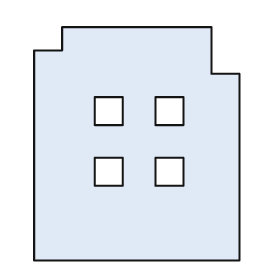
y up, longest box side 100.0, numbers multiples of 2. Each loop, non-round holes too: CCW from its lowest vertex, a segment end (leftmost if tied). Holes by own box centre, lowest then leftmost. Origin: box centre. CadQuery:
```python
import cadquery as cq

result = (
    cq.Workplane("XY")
    .moveTo(-44.0, -50.0)
    .lineTo(44.0, -50.0)
    .lineTo(44.0, 30.0)
    .lineTo(32.0, 30.0)
    .lineTo(32.0, 50.0)
    .lineTo(-32.0, 50.0)
    .lineTo(-32.0, 40.0)
    .lineTo(-44.0, 40.0)
    .close()
    .moveTo(-18.0, -18.0)
    .lineTo(-6.0, -18.0)
    .lineTo(-6.0, -6.0)
    .lineTo(-18.0, -6.0)
    .close()
    .moveTo(8.0, -18.0)
    .lineTo(20.0, -18.0)
    .lineTo(20.0, -6.0)
    .lineTo(8.0, -6.0)
    .close()
    .moveTo(-18.0, 8.0)
    .lineTo(-6.0, 8.0)
    .lineTo(-6.0, 20.0)
    .lineTo(-18.0, 20.0)
    .close()
    .moveTo(8.0, 8.0)
    .lineTo(20.0, 8.0)
    .lineTo(20.0, 20.0)
    .lineTo(8.0, 20.0)
    .close()
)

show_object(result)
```